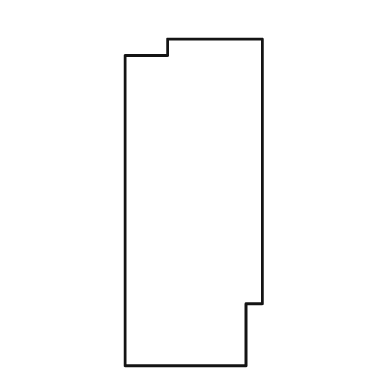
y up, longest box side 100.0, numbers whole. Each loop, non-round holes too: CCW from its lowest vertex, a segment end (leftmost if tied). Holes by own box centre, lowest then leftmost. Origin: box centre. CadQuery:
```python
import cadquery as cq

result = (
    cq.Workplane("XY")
    .moveTo(-21.0, -50.0)
    .lineTo(16.0, -50.0)
    .lineTo(16.0, -31.0)
    .lineTo(21.0, -31.0)
    .lineTo(21.0, 50.0)
    .lineTo(-8.0, 50.0)
    .lineTo(-8.0, 45.0)
    .lineTo(-21.0, 45.0)
    .close()
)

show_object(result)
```